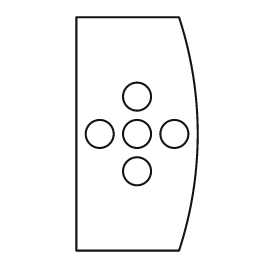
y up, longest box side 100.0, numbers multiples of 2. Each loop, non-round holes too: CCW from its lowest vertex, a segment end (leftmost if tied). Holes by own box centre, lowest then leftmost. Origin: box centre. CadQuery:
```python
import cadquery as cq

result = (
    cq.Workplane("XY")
    .moveTo(-26.0, -50.0)
    .lineTo(18.0, -50.0)
    .threePointArc((26.0, 0.0), (18.0, 50.0))
    .lineTo(-26.0, 50.0)
    .close()
    .moveTo(0.0, -16.0)
    .circle(6.0)
    .moveTo(-16.0, 0.0)
    .circle(6.0)
    .moveTo(0.0, 0.0)
    .circle(6.0)
    .moveTo(16.0, 0.0)
    .circle(6.0)
    .moveTo(0.0, 16.0)
    .circle(6.0)
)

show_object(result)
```